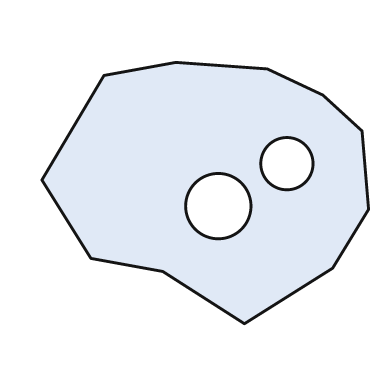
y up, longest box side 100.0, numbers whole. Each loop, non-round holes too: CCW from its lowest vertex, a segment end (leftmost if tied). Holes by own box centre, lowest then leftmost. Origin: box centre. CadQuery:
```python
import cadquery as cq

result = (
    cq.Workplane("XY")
    .moveTo(12.0, -40.0)
    .lineTo(39.0, -23.0)
    .lineTo(50.0, -5.0)
    .lineTo(48.0, 19.0)
    .lineTo(36.0, 30.0)
    .lineTo(19.0, 38.0)
    .lineTo(-9.0, 40.0)
    .lineTo(-31.0, 36.0)
    .lineTo(-50.0, 4.0)
    .lineTo(-35.0, -20.0)
    .lineTo(-13.0, -24.0)
    .close()
    .moveTo(4.0, -4.0)
    .circle(10.0)
    .moveTo(25.0, 9.0)
    .circle(8.0)
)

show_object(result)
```